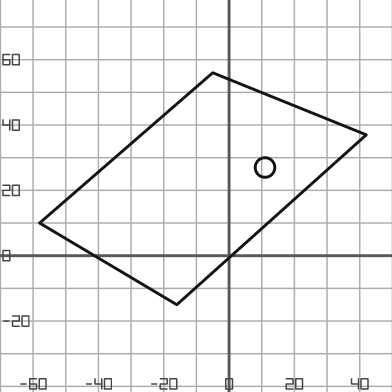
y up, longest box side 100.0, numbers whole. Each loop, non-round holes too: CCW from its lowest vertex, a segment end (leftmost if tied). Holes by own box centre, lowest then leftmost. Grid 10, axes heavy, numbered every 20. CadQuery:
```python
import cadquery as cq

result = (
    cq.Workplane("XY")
    .moveTo(-16.0, -15.0)
    .lineTo(42.0, 37.0)
    .lineTo(-5.0, 56.0)
    .lineTo(-58.0, 10.0)
    .close()
    .moveTo(11.0, 27.0)
    .circle(3.0)
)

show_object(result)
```